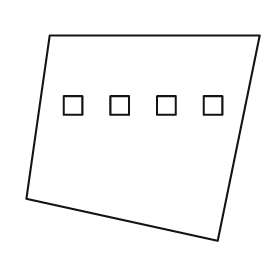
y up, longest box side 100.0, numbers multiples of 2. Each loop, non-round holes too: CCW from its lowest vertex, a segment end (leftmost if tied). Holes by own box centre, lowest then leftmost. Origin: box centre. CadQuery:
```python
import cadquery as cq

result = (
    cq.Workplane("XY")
    .moveTo(32.0, -44.0)
    .lineTo(50.0, 44.0)
    .lineTo(-40.0, 44.0)
    .lineTo(-50.0, -26.0)
    .close()
    .moveTo(-34.0, 10.0)
    .lineTo(-26.0, 10.0)
    .lineTo(-26.0, 18.0)
    .lineTo(-34.0, 18.0)
    .close()
    .moveTo(-14.0, 10.0)
    .lineTo(-6.0, 10.0)
    .lineTo(-6.0, 18.0)
    .lineTo(-14.0, 18.0)
    .close()
    .moveTo(6.0, 10.0)
    .lineTo(14.0, 10.0)
    .lineTo(14.0, 18.0)
    .lineTo(6.0, 18.0)
    .close()
    .moveTo(26.0, 10.0)
    .lineTo(34.0, 10.0)
    .lineTo(34.0, 18.0)
    .lineTo(26.0, 18.0)
    .close()
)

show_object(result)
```